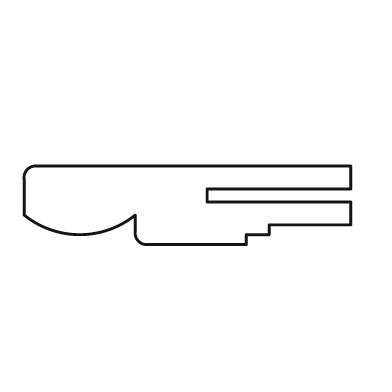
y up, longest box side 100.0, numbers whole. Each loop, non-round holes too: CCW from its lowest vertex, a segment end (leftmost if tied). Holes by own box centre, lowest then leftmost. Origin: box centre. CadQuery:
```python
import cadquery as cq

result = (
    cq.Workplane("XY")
    .moveTo(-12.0, -12.0)
    .lineTo(18.0, -12.0)
    .lineTo(18.0, -9.0)
    .lineTo(25.0, -9.0)
    .lineTo(25.0, -6.0)
    .lineTo(50.0, -6.0)
    .lineTo(50.0, 1.0)
    .lineTo(6.0, 1.0)
    .lineTo(6.0, 5.0)
    .lineTo(50.0, 5.0)
    .lineTo(50.0, 12.0)
    .lineTo(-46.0, 12.0)
    .threePointArc((-49.0, 11.0), (-50.0, 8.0))
    .lineTo(-50.0, -3.0)
    .threePointArc((-33.0, -9.0), (-16.0, -3.0))
    .lineTo(-16.0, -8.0)
    .threePointArc((-15.0, -11.0), (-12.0, -12.0))
    .close()
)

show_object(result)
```